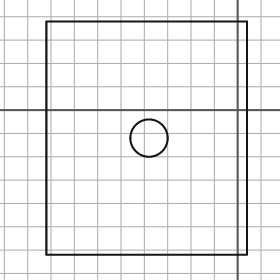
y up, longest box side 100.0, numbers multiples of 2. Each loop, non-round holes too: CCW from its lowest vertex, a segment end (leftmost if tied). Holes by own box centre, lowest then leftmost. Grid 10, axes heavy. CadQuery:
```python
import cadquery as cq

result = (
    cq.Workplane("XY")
    .moveTo(-82.0, -62.0)
    .lineTo(4.0, -62.0)
    .lineTo(4.0, 38.0)
    .lineTo(-82.0, 38.0)
    .close()
    .moveTo(-38.0, -12.0)
    .circle(8.0)
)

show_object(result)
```